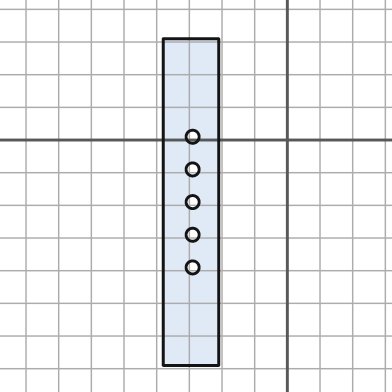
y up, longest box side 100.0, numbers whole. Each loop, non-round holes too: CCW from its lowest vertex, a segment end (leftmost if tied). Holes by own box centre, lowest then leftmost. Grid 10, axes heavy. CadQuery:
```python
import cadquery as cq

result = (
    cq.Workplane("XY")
    .moveTo(-38.0, -69.0)
    .lineTo(-21.0, -69.0)
    .lineTo(-21.0, 31.0)
    .lineTo(-38.0, 31.0)
    .close()
    .moveTo(-29.0, -39.0)
    .circle(2.0)
    .moveTo(-29.0, -29.0)
    .circle(2.0)
    .moveTo(-29.0, -19.0)
    .circle(2.0)
    .moveTo(-29.0, -9.0)
    .circle(2.0)
    .moveTo(-29.0, 1.0)
    .circle(2.0)
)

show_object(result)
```